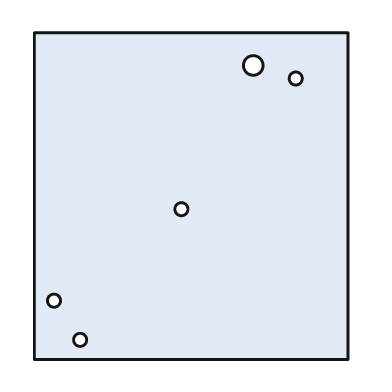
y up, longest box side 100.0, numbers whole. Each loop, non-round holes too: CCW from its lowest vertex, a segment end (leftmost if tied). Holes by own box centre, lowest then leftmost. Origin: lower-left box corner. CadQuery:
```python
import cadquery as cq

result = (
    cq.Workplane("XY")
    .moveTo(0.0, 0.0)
    .lineTo(96.0, 0.0)
    .lineTo(96.0, 100.0)
    .lineTo(0.0, 100.0)
    .close()
    .moveTo(14.0, 6.0)
    .circle(2.0)
    .moveTo(6.0, 18.0)
    .circle(2.0)
    .moveTo(45.0, 46.0)
    .circle(2.0)
    .moveTo(80.0, 86.0)
    .circle(2.0)
    .moveTo(67.0, 90.0)
    .circle(3.0)
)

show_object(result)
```